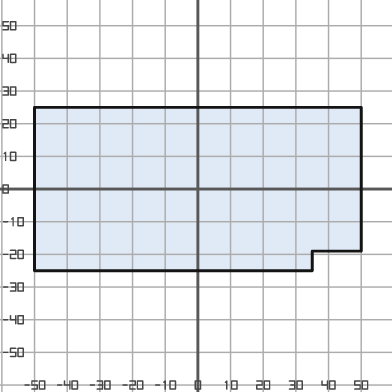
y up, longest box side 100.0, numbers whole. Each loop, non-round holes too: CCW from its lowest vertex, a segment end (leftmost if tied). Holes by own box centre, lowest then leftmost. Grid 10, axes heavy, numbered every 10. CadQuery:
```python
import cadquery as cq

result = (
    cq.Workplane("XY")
    .moveTo(-50.0, -25.0)
    .lineTo(35.0, -25.0)
    .lineTo(35.0, -19.0)
    .lineTo(50.0, -19.0)
    .lineTo(50.0, 25.0)
    .lineTo(-50.0, 25.0)
    .close()
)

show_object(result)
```